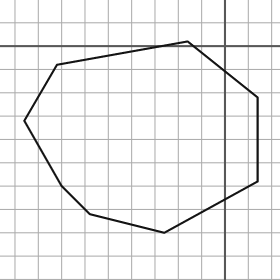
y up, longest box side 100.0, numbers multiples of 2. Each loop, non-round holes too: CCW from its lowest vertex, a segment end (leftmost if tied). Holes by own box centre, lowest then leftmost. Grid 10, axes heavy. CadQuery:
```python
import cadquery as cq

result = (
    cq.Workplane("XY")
    .moveTo(-26.0, -80.0)
    .lineTo(14.0, -58.0)
    .lineTo(14.0, -22.0)
    .lineTo(-16.0, 2.0)
    .lineTo(-72.0, -8.0)
    .lineTo(-86.0, -32.0)
    .lineTo(-70.0, -60.0)
    .lineTo(-58.0, -72.0)
    .close()
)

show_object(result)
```